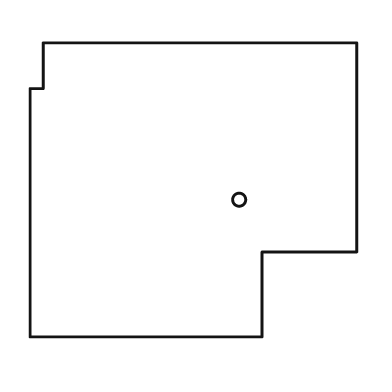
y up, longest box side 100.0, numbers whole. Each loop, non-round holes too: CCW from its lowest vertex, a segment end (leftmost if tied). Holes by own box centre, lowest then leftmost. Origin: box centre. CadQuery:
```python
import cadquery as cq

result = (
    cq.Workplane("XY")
    .moveTo(-50.0, -45.0)
    .lineTo(21.0, -45.0)
    .lineTo(21.0, -19.0)
    .lineTo(50.0, -19.0)
    .lineTo(50.0, 45.0)
    .lineTo(-46.0, 45.0)
    .lineTo(-46.0, 31.0)
    .lineTo(-50.0, 31.0)
    .close()
    .moveTo(14.0, -3.0)
    .circle(2.0)
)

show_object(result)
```